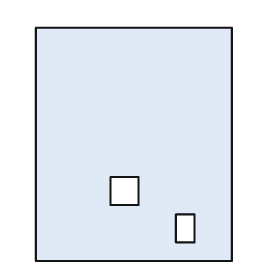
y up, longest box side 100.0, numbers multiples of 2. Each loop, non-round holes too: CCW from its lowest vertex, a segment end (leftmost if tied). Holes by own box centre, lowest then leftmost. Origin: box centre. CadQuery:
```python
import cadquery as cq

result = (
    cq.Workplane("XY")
    .moveTo(-42.0, -50.0)
    .lineTo(42.0, -50.0)
    .lineTo(42.0, 50.0)
    .lineTo(-42.0, 50.0)
    .close()
    .moveTo(18.0, -42.0)
    .lineTo(26.0, -42.0)
    .lineTo(26.0, -30.0)
    .lineTo(18.0, -30.0)
    .close()
    .moveTo(-10.0, -26.0)
    .lineTo(2.0, -26.0)
    .lineTo(2.0, -14.0)
    .lineTo(-10.0, -14.0)
    .close()
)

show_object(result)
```